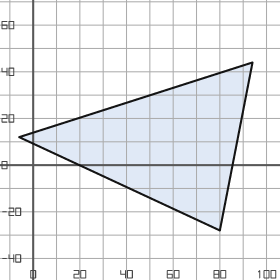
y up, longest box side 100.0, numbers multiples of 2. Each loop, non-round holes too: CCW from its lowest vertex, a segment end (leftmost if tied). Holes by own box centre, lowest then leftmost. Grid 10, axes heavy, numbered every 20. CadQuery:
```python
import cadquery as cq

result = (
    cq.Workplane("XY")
    .moveTo(80.0, -28.0)
    .lineTo(94.0, 44.0)
    .lineTo(-6.0, 12.0)
    .close()
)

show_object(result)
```